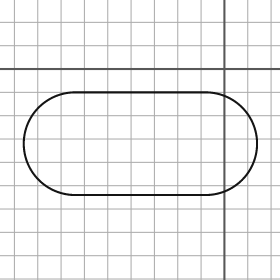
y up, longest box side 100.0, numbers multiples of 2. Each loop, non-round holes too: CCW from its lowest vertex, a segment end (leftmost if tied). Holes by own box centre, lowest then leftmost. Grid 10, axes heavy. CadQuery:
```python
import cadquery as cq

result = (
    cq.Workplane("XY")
    .moveTo(-64.0, -54.0)
    .lineTo(-8.0, -54.0)
    .threePointArc((14.0, -32.0), (-8.0, -10.0))
    .lineTo(-64.0, -10.0)
    .threePointArc((-86.0, -32.0), (-64.0, -54.0))
    .close()
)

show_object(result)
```